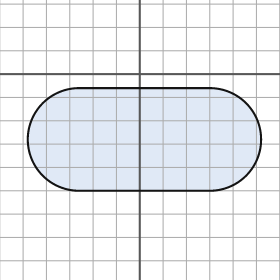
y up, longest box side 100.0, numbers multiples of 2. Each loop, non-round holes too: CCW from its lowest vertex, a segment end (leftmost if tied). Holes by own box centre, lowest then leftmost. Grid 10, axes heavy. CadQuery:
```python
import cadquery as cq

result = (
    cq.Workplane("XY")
    .moveTo(-26.0, -50.0)
    .lineTo(30.0, -50.0)
    .threePointArc((52.0, -28.0), (30.0, -6.0))
    .lineTo(-26.0, -6.0)
    .threePointArc((-48.0, -28.0), (-26.0, -50.0))
    .close()
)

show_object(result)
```